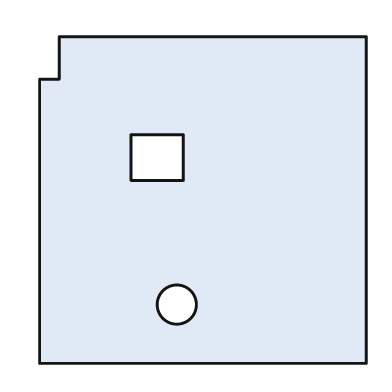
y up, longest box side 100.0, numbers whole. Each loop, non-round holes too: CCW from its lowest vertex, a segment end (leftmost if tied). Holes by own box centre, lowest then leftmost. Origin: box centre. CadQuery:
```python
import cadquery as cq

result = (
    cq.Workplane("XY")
    .moveTo(-50.0, -50.0)
    .lineTo(50.0, -50.0)
    .lineTo(50.0, 50.0)
    .lineTo(-44.0, 50.0)
    .lineTo(-44.0, 37.0)
    .lineTo(-50.0, 37.0)
    .close()
    .moveTo(-8.0, -32.0)
    .circle(6.0)
    .moveTo(-22.0, 6.0)
    .lineTo(-6.0, 6.0)
    .lineTo(-6.0, 20.0)
    .lineTo(-22.0, 20.0)
    .close()
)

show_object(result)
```